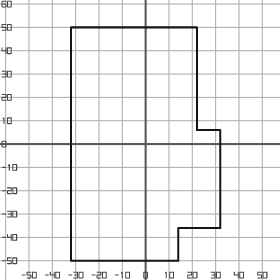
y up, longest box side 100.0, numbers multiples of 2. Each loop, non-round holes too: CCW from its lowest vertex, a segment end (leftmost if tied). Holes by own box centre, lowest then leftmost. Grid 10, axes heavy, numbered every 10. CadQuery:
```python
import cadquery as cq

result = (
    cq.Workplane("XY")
    .moveTo(-32.0, -50.0)
    .lineTo(14.0, -50.0)
    .lineTo(14.0, -36.0)
    .lineTo(32.0, -36.0)
    .lineTo(32.0, 6.0)
    .lineTo(22.0, 6.0)
    .lineTo(22.0, 50.0)
    .lineTo(-32.0, 50.0)
    .close()
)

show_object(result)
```